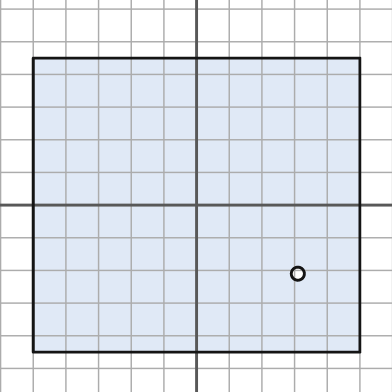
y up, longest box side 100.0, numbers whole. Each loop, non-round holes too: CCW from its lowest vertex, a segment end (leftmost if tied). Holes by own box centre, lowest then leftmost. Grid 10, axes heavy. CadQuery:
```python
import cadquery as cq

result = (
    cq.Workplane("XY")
    .moveTo(-50.0, -45.0)
    .lineTo(50.0, -45.0)
    .lineTo(50.0, 45.0)
    .lineTo(-50.0, 45.0)
    .close()
    .moveTo(31.0, -21.0)
    .circle(2.0)
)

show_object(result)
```